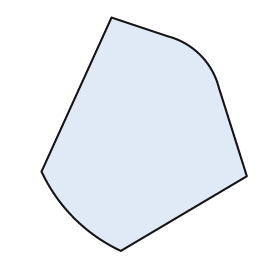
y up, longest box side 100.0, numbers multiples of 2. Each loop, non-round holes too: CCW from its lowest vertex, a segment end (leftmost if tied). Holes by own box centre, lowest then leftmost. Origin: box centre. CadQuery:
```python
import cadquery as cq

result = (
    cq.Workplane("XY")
    .moveTo(-10.0, -50.0)
    .lineTo(44.0, -18.0)
    .lineTo(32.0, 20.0)
    .threePointArc((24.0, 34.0), (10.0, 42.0))
    .lineTo(-14.0, 50.0)
    .lineTo(-44.0, -16.0)
    .threePointArc((-30.0, -36.0), (-10.0, -50.0))
    .close()
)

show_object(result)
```